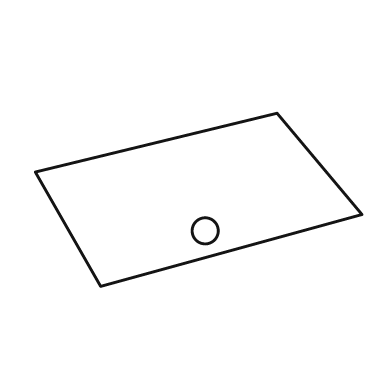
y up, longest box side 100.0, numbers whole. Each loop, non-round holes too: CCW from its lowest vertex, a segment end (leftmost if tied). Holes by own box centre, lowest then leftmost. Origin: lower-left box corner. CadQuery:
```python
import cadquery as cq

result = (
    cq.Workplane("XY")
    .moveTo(20.0, 0.0)
    .lineTo(100.0, 22.0)
    .lineTo(74.0, 53.0)
    .lineTo(0.0, 35.0)
    .close()
    .moveTo(52.0, 17.0)
    .circle(4.0)
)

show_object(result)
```